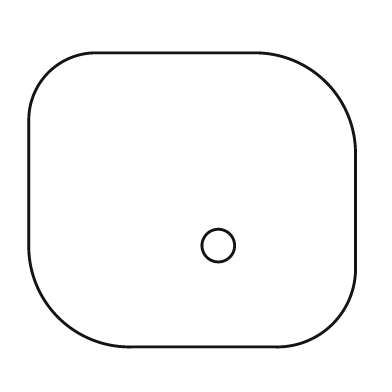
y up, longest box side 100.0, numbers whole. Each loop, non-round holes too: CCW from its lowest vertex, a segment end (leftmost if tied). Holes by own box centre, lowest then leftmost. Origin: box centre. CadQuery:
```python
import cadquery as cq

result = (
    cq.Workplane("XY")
    .moveTo(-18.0, -45.0)
    .lineTo(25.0, -45.0)
    .threePointArc((43.0, -38.0), (50.0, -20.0))
    .lineTo(50.0, 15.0)
    .threePointArc((41.0, 36.0), (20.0, 45.0))
    .lineTo(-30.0, 45.0)
    .threePointArc((-44.0, 39.0), (-50.0, 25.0))
    .lineTo(-50.0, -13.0)
    .threePointArc((-41.0, -36.0), (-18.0, -45.0))
    .close()
    .moveTo(8.0, -14.0)
    .circle(5.0)
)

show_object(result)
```